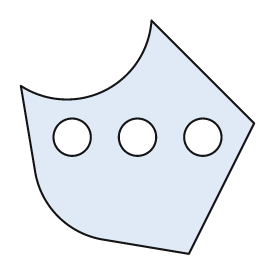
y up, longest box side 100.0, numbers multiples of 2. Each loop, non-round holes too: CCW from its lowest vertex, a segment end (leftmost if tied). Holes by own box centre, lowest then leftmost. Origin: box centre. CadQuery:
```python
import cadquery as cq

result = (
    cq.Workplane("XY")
    .moveTo(22.0, -50.0)
    .lineTo(50.0, 6.0)
    .lineTo(6.0, 50.0)
    .threePointArc((-14.0, 20.0), (-50.0, 22.0))
    .lineTo(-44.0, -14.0)
    .threePointArc((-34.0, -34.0), (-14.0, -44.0))
    .close()
    .moveTo(-28.0, 0.0)
    .circle(8.0)
    .moveTo(0.0, 0.0)
    .circle(8.0)
    .moveTo(28.0, 0.0)
    .circle(8.0)
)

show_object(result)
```